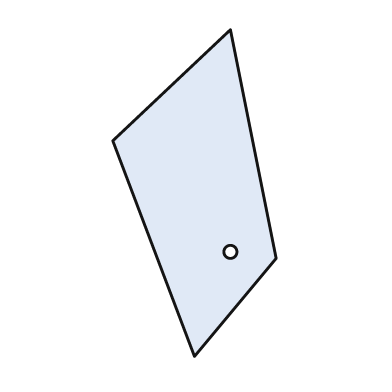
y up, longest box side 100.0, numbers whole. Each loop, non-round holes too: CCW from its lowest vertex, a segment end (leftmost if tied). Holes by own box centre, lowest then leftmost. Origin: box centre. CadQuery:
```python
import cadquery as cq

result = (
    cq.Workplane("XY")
    .moveTo(0.0, -50.0)
    .lineTo(25.0, -20.0)
    .lineTo(11.0, 50.0)
    .lineTo(-25.0, 16.0)
    .close()
    .moveTo(11.0, -18.0)
    .circle(2.0)
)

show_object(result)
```